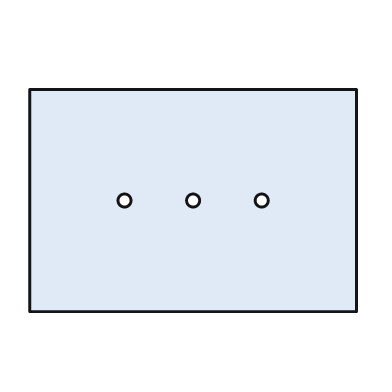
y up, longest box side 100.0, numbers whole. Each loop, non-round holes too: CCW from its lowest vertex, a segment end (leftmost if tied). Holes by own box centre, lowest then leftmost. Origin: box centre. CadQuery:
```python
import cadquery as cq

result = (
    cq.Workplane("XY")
    .moveTo(-50.0, -34.0)
    .lineTo(50.0, -34.0)
    .lineTo(50.0, 34.0)
    .lineTo(-50.0, 34.0)
    .close()
    .moveTo(-21.0, 0.0)
    .circle(2.0)
    .moveTo(0.0, 0.0)
    .circle(2.0)
    .moveTo(21.0, 0.0)
    .circle(2.0)
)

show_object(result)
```